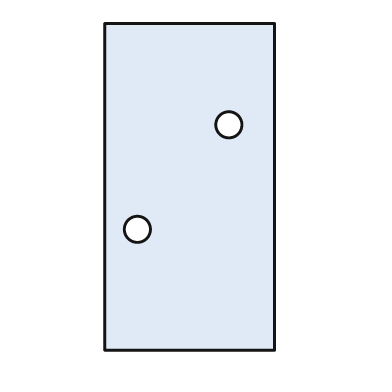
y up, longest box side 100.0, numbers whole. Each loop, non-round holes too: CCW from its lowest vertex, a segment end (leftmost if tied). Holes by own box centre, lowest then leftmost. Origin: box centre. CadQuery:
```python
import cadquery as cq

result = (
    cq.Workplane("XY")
    .moveTo(-26.0, -50.0)
    .lineTo(26.0, -50.0)
    .lineTo(26.0, 50.0)
    .lineTo(-26.0, 50.0)
    .close()
    .moveTo(-16.0, -13.0)
    .circle(4.0)
    .moveTo(12.0, 19.0)
    .circle(4.0)
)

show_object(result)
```